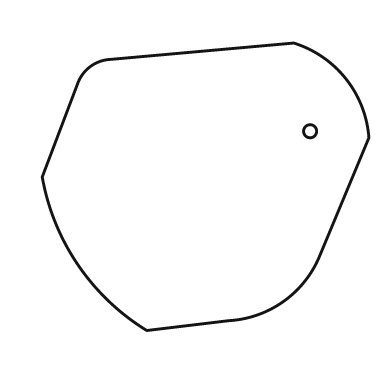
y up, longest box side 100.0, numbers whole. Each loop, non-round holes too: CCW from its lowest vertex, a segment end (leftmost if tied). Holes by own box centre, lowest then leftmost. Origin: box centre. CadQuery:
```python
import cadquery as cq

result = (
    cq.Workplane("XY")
    .moveTo(-18.0, -44.0)
    .lineTo(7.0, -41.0)
    .threePointArc((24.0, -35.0), (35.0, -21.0))
    .lineTo(50.0, 15.0)
    .threePointArc((43.0, 33.0), (27.0, 44.0))
    .lineTo(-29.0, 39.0)
    .threePointArc((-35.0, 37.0), (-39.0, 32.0))
    .lineTo(-50.0, 3.0)
    .threePointArc((-39.0, -24.0), (-18.0, -44.0))
    .close()
    .moveTo(32.0, 17.0)
    .circle(2.0)
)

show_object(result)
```